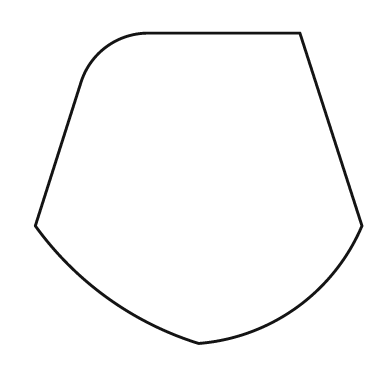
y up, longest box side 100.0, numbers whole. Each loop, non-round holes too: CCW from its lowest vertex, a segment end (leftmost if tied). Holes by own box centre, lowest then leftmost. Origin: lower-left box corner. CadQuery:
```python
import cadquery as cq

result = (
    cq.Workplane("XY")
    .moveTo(50.0, 0.0)
    .threePointArc((80.0, 11.0), (100.0, 36.0))
    .lineTo(81.0, 95.0)
    .lineTo(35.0, 95.0)
    .threePointArc((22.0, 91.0), (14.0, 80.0))
    .lineTo(0.0, 36.0)
    .threePointArc((22.0, 14.0), (50.0, 0.0))
    .close()
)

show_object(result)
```